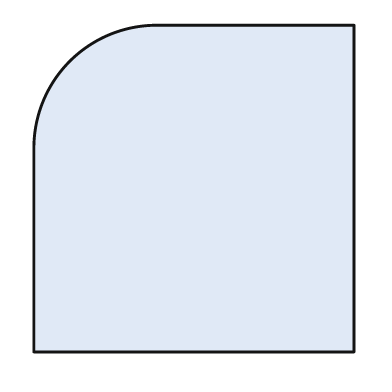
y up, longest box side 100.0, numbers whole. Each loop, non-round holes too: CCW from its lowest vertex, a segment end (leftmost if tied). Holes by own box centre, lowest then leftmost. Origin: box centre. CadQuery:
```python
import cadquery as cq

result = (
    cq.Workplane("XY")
    .moveTo(-49.0, -50.0)
    .lineTo(49.0, -50.0)
    .lineTo(49.0, 50.0)
    .lineTo(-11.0, 50.0)
    .threePointArc((-38.0, 39.0), (-49.0, 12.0))
    .close()
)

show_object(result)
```